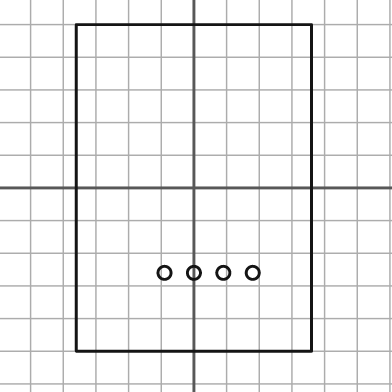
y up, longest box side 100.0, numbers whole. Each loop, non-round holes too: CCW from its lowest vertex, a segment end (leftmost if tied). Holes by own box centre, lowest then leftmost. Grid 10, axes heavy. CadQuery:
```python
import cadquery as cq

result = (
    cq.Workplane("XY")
    .moveTo(-36.0, -50.0)
    .lineTo(36.0, -50.0)
    .lineTo(36.0, 50.0)
    .lineTo(-36.0, 50.0)
    .close()
    .moveTo(-9.0, -26.0)
    .circle(2.0)
    .moveTo(0.0, -26.0)
    .circle(2.0)
    .moveTo(9.0, -26.0)
    .circle(2.0)
    .moveTo(18.0, -26.0)
    .circle(2.0)
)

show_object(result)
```